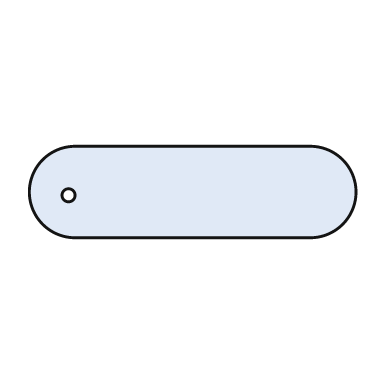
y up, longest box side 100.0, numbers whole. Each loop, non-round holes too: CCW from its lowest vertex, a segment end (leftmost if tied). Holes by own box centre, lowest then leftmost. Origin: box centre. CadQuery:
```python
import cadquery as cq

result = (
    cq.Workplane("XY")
    .moveTo(-36.0, -14.0)
    .lineTo(36.0, -14.0)
    .threePointArc((50.0, 0.0), (36.0, 14.0))
    .lineTo(-36.0, 14.0)
    .threePointArc((-50.0, 0.0), (-36.0, -14.0))
    .close()
    .moveTo(-38.0, -1.0)
    .circle(2.0)
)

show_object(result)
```